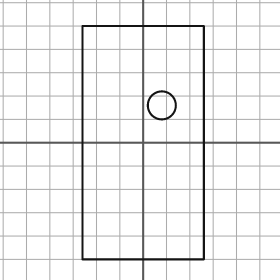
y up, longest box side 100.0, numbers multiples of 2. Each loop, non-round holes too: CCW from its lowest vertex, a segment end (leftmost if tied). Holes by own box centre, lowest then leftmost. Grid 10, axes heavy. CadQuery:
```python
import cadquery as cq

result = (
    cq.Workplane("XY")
    .moveTo(-26.0, -50.0)
    .lineTo(26.0, -50.0)
    .lineTo(26.0, 50.0)
    .lineTo(-26.0, 50.0)
    .close()
    .moveTo(8.0, 16.0)
    .circle(6.0)
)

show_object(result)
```